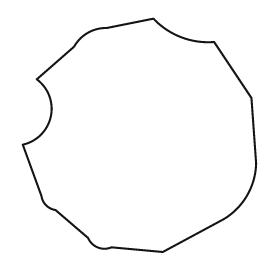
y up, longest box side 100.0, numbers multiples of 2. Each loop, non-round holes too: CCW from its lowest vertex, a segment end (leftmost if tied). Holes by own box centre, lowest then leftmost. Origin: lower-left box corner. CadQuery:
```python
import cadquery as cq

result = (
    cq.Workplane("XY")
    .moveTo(60.0, 0.0)
    .lineTo(86.0, 14.0)
    .threePointArc((96.0, 24.0), (100.0, 38.0))
    .lineTo(98.0, 66.0)
    .lineTo(82.0, 90.0)
    .threePointArc((68.0, 92.0), (56.0, 100.0))
    .lineTo(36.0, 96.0)
    .threePointArc((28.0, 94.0), (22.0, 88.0))
    .lineTo(6.0, 74.0)
    .threePointArc((12.0, 58.0), (0.0, 46.0))
    .lineTo(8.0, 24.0)
    .threePointArc((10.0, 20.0), (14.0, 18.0))
    .lineTo(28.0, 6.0)
    .threePointArc((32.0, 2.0), (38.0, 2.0))
    .close()
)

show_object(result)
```